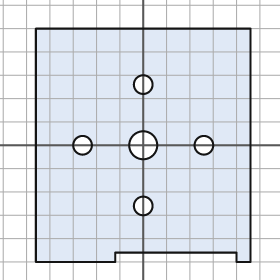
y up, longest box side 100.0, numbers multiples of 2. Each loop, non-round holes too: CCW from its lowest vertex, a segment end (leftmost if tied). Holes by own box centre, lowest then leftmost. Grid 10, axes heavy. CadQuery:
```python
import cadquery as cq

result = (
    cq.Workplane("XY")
    .moveTo(-46.0, -50.0)
    .lineTo(-12.0, -50.0)
    .lineTo(-12.0, -46.0)
    .lineTo(40.0, -46.0)
    .lineTo(40.0, -50.0)
    .lineTo(46.0, -50.0)
    .lineTo(46.0, 50.0)
    .lineTo(-46.0, 50.0)
    .close()
    .moveTo(0.0, -26.0)
    .circle(4.0)
    .moveTo(-26.0, 0.0)
    .circle(4.0)
    .moveTo(0.0, 0.0)
    .circle(6.0)
    .moveTo(26.0, 0.0)
    .circle(4.0)
    .moveTo(0.0, 26.0)
    .circle(4.0)
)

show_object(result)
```